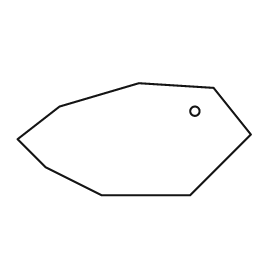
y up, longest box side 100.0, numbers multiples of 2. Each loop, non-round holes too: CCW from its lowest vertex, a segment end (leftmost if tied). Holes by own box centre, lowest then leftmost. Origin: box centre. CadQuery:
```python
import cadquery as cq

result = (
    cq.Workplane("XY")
    .moveTo(-14.0, -24.0)
    .lineTo(24.0, -24.0)
    .lineTo(50.0, 2.0)
    .lineTo(34.0, 22.0)
    .lineTo(2.0, 24.0)
    .lineTo(-32.0, 14.0)
    .lineTo(-50.0, 0.0)
    .lineTo(-38.0, -12.0)
    .close()
    .moveTo(26.0, 12.0)
    .circle(2.0)
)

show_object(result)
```